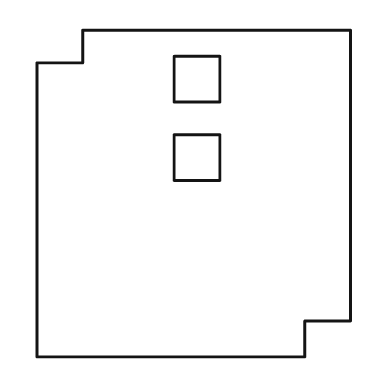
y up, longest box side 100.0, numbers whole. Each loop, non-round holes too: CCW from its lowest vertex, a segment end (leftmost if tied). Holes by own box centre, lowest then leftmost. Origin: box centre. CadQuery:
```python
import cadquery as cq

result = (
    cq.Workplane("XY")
    .moveTo(-48.0, -50.0)
    .lineTo(34.0, -50.0)
    .lineTo(34.0, -39.0)
    .lineTo(48.0, -39.0)
    .lineTo(48.0, 50.0)
    .lineTo(-34.0, 50.0)
    .lineTo(-34.0, 40.0)
    .lineTo(-48.0, 40.0)
    .close()
    .moveTo(-6.0, 4.0)
    .lineTo(8.0, 4.0)
    .lineTo(8.0, 18.0)
    .lineTo(-6.0, 18.0)
    .close()
    .moveTo(-6.0, 28.0)
    .lineTo(8.0, 28.0)
    .lineTo(8.0, 42.0)
    .lineTo(-6.0, 42.0)
    .close()
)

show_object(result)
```